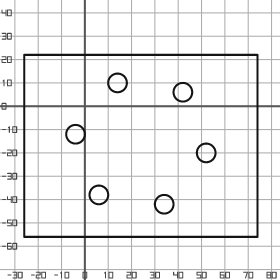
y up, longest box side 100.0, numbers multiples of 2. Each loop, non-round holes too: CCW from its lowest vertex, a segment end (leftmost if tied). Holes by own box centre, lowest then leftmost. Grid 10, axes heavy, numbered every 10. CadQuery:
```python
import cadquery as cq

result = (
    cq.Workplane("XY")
    .moveTo(-26.0, -56.0)
    .lineTo(74.0, -56.0)
    .lineTo(74.0, 22.0)
    .lineTo(-26.0, 22.0)
    .close()
    .moveTo(34.0, -42.0)
    .circle(4.0)
    .moveTo(6.0, -38.0)
    .circle(4.0)
    .moveTo(52.0, -20.0)
    .circle(4.0)
    .moveTo(-4.0, -12.0)
    .circle(4.0)
    .moveTo(42.0, 6.0)
    .circle(4.0)
    .moveTo(14.0, 10.0)
    .circle(4.0)
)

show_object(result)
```